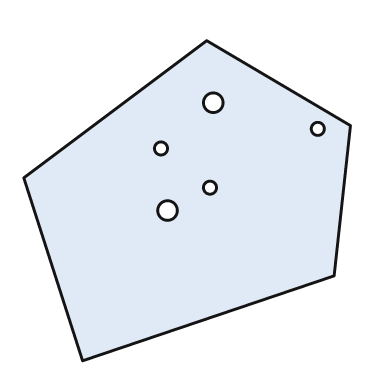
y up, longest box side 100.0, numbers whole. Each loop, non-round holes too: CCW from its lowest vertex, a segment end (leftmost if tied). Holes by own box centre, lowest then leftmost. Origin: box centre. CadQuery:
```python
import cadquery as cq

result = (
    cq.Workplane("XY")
    .moveTo(-32.0, -49.0)
    .lineTo(45.0, -23.0)
    .lineTo(50.0, 23.0)
    .lineTo(6.0, 49.0)
    .lineTo(-50.0, 7.0)
    .close()
    .moveTo(-6.0, -3.0)
    .circle(3.0)
    .moveTo(7.0, 4.0)
    .circle(2.0)
    .moveTo(-8.0, 16.0)
    .circle(2.0)
    .moveTo(40.0, 22.0)
    .circle(2.0)
    .moveTo(8.0, 30.0)
    .circle(3.0)
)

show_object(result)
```